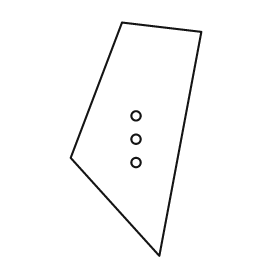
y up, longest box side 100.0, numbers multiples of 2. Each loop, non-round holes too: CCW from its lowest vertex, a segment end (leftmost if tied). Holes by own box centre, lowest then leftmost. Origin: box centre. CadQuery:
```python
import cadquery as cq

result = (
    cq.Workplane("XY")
    .moveTo(10.0, -50.0)
    .lineTo(28.0, 46.0)
    .lineTo(-6.0, 50.0)
    .lineTo(-28.0, -8.0)
    .close()
    .moveTo(0.0, -10.0)
    .circle(2.0)
    .moveTo(0.0, 0.0)
    .circle(2.0)
    .moveTo(0.0, 10.0)
    .circle(2.0)
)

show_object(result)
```